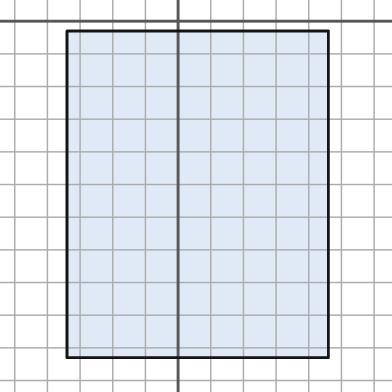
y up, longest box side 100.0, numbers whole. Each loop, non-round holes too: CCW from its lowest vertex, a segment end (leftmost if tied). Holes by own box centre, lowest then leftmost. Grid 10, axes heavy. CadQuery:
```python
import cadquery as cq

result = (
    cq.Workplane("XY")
    .moveTo(-34.0, -103.0)
    .lineTo(46.0, -103.0)
    .lineTo(46.0, -3.0)
    .lineTo(-34.0, -3.0)
    .close()
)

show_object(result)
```